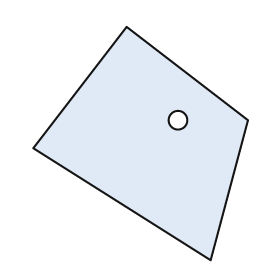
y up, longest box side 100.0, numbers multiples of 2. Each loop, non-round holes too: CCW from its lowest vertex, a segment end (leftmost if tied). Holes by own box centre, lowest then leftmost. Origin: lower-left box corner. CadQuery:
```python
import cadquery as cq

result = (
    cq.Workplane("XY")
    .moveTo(76.0, 0.0)
    .lineTo(92.0, 60.0)
    .lineTo(40.0, 100.0)
    .lineTo(0.0, 48.0)
    .close()
    .moveTo(62.0, 60.0)
    .circle(4.0)
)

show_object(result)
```